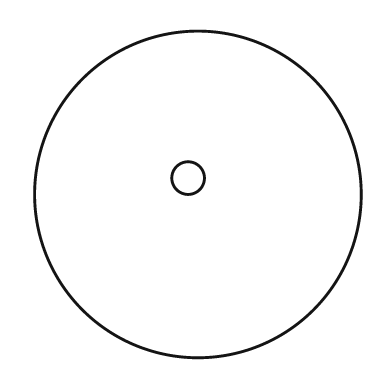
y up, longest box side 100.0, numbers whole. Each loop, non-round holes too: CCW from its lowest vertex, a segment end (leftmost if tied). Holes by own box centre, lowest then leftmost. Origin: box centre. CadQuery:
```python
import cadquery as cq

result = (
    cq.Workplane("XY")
    .moveTo(0.0, 0.0)
    .circle(50.0)
    .moveTo(-3.0, 5.0)
    .circle(5.0)
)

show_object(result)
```